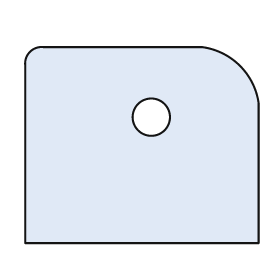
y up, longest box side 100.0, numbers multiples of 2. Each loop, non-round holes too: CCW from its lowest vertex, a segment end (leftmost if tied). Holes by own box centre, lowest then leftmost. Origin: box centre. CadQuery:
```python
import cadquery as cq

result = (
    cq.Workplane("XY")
    .moveTo(-50.0, -42.0)
    .lineTo(50.0, -42.0)
    .lineTo(50.0, 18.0)
    .threePointArc((42.0, 34.0), (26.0, 42.0))
    .lineTo(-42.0, 42.0)
    .threePointArc((-48.0, 40.0), (-50.0, 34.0))
    .close()
    .moveTo(4.0, 12.0)
    .circle(8.0)
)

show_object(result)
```